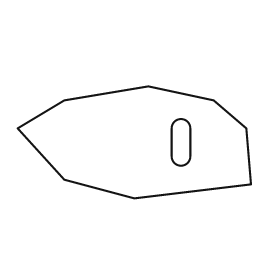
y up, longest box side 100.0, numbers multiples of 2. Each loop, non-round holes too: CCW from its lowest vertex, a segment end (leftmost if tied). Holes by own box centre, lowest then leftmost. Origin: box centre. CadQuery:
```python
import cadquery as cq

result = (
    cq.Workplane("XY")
    .moveTo(0.0, -24.0)
    .lineTo(50.0, -18.0)
    .lineTo(48.0, 6.0)
    .lineTo(34.0, 18.0)
    .lineTo(6.0, 24.0)
    .lineTo(-30.0, 18.0)
    .lineTo(-50.0, 6.0)
    .lineTo(-30.0, -16.0)
    .close()
    .moveTo(16.0, -6.0)
    .threePointArc((20.0, -10.0), (24.0, -6.0))
    .lineTo(24.0, 6.0)
    .threePointArc((20.0, 10.0), (16.0, 6.0))
    .close()
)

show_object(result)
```